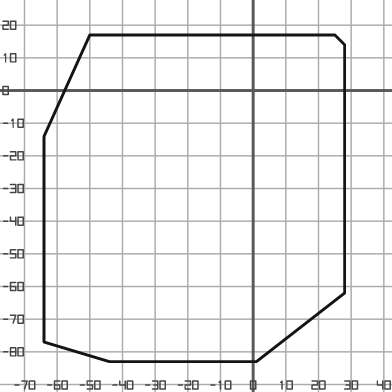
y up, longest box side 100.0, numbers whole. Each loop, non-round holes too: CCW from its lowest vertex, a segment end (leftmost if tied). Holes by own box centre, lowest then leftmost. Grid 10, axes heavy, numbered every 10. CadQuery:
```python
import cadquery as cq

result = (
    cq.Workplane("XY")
    .moveTo(-44.0, -83.0)
    .lineTo(1.0, -83.0)
    .lineTo(28.0, -62.0)
    .lineTo(28.0, 14.0)
    .lineTo(25.0, 17.0)
    .lineTo(-50.0, 17.0)
    .lineTo(-64.0, -14.0)
    .lineTo(-64.0, -77.0)
    .close()
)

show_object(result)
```